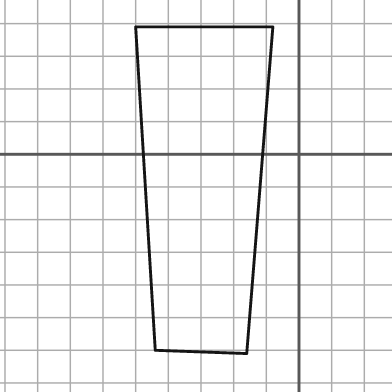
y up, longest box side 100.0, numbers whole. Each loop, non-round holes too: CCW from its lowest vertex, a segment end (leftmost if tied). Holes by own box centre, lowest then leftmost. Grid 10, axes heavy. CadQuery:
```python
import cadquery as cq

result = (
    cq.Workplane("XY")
    .moveTo(-16.0, -61.0)
    .lineTo(-8.0, 39.0)
    .lineTo(-50.0, 39.0)
    .lineTo(-44.0, -60.0)
    .close()
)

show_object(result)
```